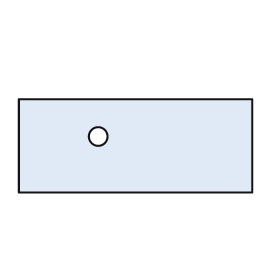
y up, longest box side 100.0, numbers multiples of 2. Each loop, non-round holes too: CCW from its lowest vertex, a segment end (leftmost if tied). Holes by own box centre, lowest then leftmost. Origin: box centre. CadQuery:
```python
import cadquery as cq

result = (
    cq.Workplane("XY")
    .moveTo(-50.0, -20.0)
    .lineTo(50.0, -20.0)
    .lineTo(50.0, 20.0)
    .lineTo(-50.0, 20.0)
    .close()
    .moveTo(-16.0, 4.0)
    .circle(4.0)
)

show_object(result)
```